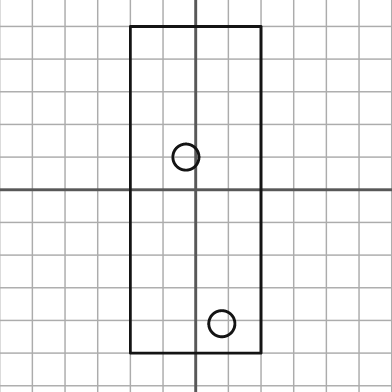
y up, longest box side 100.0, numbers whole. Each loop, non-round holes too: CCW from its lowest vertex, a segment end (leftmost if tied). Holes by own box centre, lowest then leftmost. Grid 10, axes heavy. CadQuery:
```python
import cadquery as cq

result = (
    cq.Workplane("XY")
    .moveTo(-20.0, -50.0)
    .lineTo(20.0, -50.0)
    .lineTo(20.0, 50.0)
    .lineTo(-20.0, 50.0)
    .close()
    .moveTo(8.0, -41.0)
    .circle(4.0)
    .moveTo(-3.0, 10.0)
    .circle(4.0)
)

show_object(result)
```